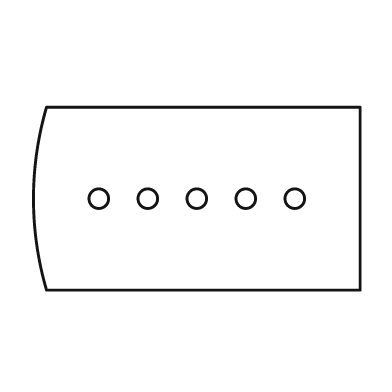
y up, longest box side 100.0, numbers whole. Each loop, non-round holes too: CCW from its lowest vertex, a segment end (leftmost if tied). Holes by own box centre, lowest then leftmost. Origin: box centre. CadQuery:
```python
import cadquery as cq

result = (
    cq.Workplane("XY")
    .moveTo(-46.0, -28.0)
    .lineTo(50.0, -28.0)
    .lineTo(50.0, 28.0)
    .lineTo(-46.0, 28.0)
    .threePointArc((-50.0, 0.0), (-46.0, -28.0))
    .close()
    .moveTo(-30.0, 0.0)
    .circle(3.0)
    .moveTo(-15.0, 0.0)
    .circle(3.0)
    .moveTo(0.0, 0.0)
    .circle(3.0)
    .moveTo(15.0, 0.0)
    .circle(3.0)
    .moveTo(30.0, 0.0)
    .circle(3.0)
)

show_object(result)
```